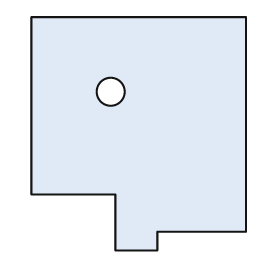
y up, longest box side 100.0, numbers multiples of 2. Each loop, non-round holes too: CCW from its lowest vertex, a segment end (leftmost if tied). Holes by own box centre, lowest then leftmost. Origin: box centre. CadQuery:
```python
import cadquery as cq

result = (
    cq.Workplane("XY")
    .moveTo(-10.0, -50.0)
    .lineTo(8.0, -50.0)
    .lineTo(8.0, -42.0)
    .lineTo(46.0, -42.0)
    .lineTo(46.0, 50.0)
    .lineTo(-46.0, 50.0)
    .lineTo(-46.0, -26.0)
    .lineTo(-10.0, -26.0)
    .close()
    .moveTo(-12.0, 18.0)
    .circle(6.0)
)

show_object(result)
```